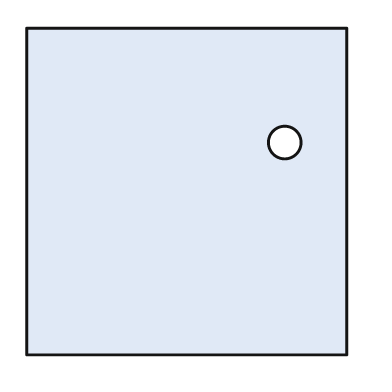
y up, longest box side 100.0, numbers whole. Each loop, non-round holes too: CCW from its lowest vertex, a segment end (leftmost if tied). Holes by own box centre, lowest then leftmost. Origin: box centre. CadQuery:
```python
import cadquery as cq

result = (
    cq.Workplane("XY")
    .moveTo(-49.0, -50.0)
    .lineTo(49.0, -50.0)
    .lineTo(49.0, 50.0)
    .lineTo(-49.0, 50.0)
    .close()
    .moveTo(30.0, 15.0)
    .circle(5.0)
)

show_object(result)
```